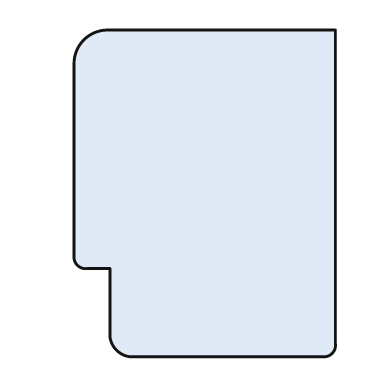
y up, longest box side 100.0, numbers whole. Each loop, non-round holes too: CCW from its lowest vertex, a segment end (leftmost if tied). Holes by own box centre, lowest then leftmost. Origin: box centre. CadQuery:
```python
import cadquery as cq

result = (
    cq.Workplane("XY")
    .moveTo(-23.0, -50.0)
    .lineTo(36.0, -50.0)
    .threePointArc((39.0, -49.0), (40.0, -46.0))
    .lineTo(40.0, 50.0)
    .lineTo(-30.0, 50.0)
    .threePointArc((-37.0, 47.0), (-40.0, 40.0))
    .lineTo(-40.0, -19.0)
    .threePointArc((-39.0, -22.0), (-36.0, -23.0))
    .lineTo(-29.0, -23.0)
    .lineTo(-29.0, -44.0)
    .threePointArc((-27.0, -48.0), (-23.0, -50.0))
    .close()
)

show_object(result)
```